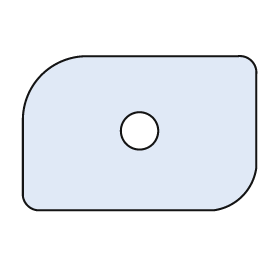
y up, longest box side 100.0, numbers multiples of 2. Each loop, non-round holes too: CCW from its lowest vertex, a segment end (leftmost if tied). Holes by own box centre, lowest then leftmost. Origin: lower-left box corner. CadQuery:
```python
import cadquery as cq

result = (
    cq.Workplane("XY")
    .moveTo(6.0, 0.0)
    .lineTo(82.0, 0.0)
    .threePointArc((94.0, 6.0), (100.0, 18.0))
    .lineTo(100.0, 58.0)
    .threePointArc((98.0, 64.0), (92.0, 66.0))
    .lineTo(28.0, 66.0)
    .threePointArc((8.0, 58.0), (0.0, 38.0))
    .lineTo(0.0, 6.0)
    .threePointArc((2.0, 2.0), (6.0, 0.0))
    .close()
    .moveTo(50.0, 34.0)
    .circle(8.0)
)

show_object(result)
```